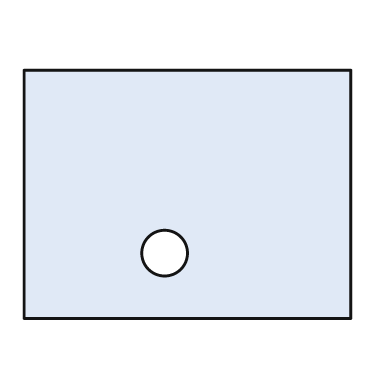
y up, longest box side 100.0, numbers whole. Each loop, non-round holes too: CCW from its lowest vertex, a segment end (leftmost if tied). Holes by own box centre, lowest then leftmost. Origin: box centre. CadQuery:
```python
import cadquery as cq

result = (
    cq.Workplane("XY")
    .moveTo(-50.0, -38.0)
    .lineTo(50.0, -38.0)
    .lineTo(50.0, 38.0)
    .lineTo(-50.0, 38.0)
    .close()
    .moveTo(-7.0, -18.0)
    .circle(7.0)
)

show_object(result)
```